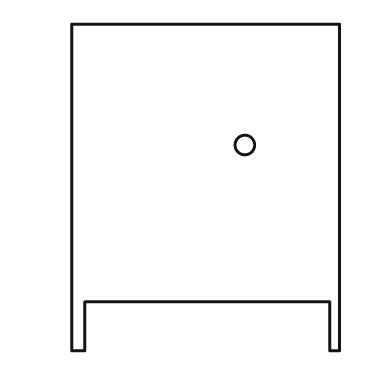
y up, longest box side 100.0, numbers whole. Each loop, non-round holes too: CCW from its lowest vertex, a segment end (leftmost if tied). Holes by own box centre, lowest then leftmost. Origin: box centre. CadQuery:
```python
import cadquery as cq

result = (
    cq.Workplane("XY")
    .moveTo(-41.0, -50.0)
    .lineTo(-37.0, -50.0)
    .lineTo(-37.0, -35.0)
    .lineTo(38.0, -35.0)
    .lineTo(38.0, -50.0)
    .lineTo(41.0, -50.0)
    .lineTo(41.0, 50.0)
    .lineTo(-41.0, 50.0)
    .close()
    .moveTo(12.0, 13.0)
    .circle(3.0)
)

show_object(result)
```